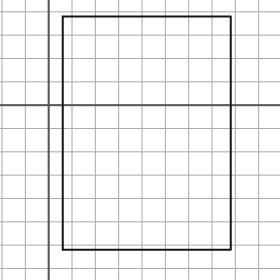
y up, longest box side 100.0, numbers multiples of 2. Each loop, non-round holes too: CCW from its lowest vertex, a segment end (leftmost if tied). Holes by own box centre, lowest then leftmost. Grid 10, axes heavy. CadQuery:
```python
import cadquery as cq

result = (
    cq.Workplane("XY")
    .moveTo(6.0, -62.0)
    .lineTo(78.0, -62.0)
    .lineTo(78.0, 38.0)
    .lineTo(6.0, 38.0)
    .close()
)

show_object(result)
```